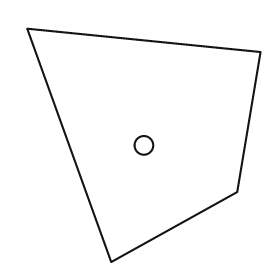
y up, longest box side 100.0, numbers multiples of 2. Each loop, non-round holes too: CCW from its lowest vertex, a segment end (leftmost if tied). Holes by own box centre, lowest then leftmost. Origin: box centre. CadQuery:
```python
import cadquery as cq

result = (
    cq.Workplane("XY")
    .moveTo(-14.0, -50.0)
    .lineTo(40.0, -20.0)
    .lineTo(50.0, 40.0)
    .lineTo(-50.0, 50.0)
    .close()
    .moveTo(0.0, 0.0)
    .circle(4.0)
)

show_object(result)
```